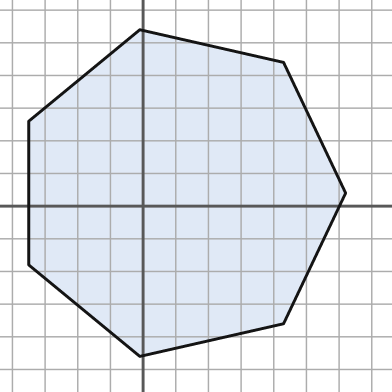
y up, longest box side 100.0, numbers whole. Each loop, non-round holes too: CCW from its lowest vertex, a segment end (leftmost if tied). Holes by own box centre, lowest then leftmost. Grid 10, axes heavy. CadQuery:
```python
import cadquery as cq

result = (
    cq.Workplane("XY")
    .moveTo(-1.0, -46.0)
    .lineTo(43.0, -36.0)
    .lineTo(62.0, 4.0)
    .lineTo(43.0, 44.0)
    .lineTo(-1.0, 54.0)
    .lineTo(-35.0, 26.0)
    .lineTo(-35.0, -18.0)
    .close()
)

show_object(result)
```